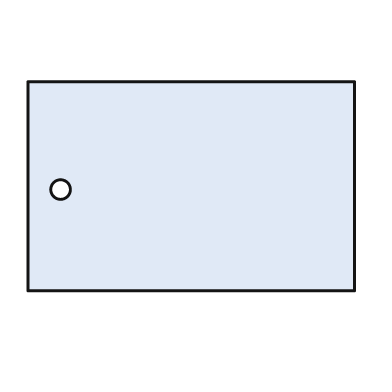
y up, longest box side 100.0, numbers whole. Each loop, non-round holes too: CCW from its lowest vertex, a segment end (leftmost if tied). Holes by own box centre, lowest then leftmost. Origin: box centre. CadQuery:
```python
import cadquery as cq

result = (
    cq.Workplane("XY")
    .moveTo(-50.0, -32.0)
    .lineTo(50.0, -32.0)
    .lineTo(50.0, 32.0)
    .lineTo(-50.0, 32.0)
    .close()
    .moveTo(-40.0, -1.0)
    .circle(3.0)
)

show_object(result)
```